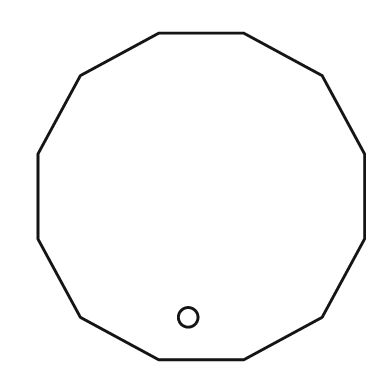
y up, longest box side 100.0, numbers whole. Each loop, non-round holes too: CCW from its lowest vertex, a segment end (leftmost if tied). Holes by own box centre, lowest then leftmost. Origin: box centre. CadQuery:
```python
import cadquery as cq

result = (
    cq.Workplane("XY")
    .moveTo(-13.0, -50.0)
    .lineTo(13.0, -50.0)
    .lineTo(37.0, -37.0)
    .lineTo(50.0, -13.0)
    .lineTo(50.0, 13.0)
    .lineTo(37.0, 37.0)
    .lineTo(13.0, 50.0)
    .lineTo(-13.0, 50.0)
    .lineTo(-37.0, 37.0)
    .lineTo(-50.0, 13.0)
    .lineTo(-50.0, -13.0)
    .lineTo(-37.0, -37.0)
    .close()
    .moveTo(-4.0, -37.0)
    .circle(3.0)
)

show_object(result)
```